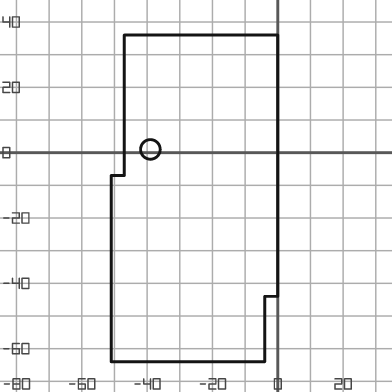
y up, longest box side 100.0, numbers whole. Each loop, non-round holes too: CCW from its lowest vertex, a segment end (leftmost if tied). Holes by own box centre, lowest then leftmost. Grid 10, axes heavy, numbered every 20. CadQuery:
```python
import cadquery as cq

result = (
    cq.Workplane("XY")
    .moveTo(-51.0, -64.0)
    .lineTo(-4.0, -64.0)
    .lineTo(-4.0, -44.0)
    .lineTo(0.0, -44.0)
    .lineTo(0.0, 36.0)
    .lineTo(-47.0, 36.0)
    .lineTo(-47.0, -7.0)
    .lineTo(-51.0, -7.0)
    .close()
    .moveTo(-39.0, 1.0)
    .circle(3.0)
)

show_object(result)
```